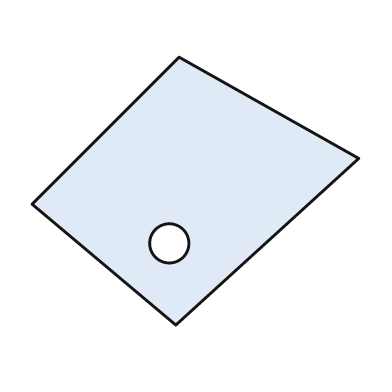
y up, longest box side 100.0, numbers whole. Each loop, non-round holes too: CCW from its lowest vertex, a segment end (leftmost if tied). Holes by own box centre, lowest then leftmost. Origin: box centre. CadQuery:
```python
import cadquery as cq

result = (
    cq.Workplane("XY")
    .moveTo(-6.0, -41.0)
    .lineTo(50.0, 10.0)
    .lineTo(-5.0, 41.0)
    .lineTo(-50.0, -4.0)
    .close()
    .moveTo(-8.0, -16.0)
    .circle(6.0)
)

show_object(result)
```